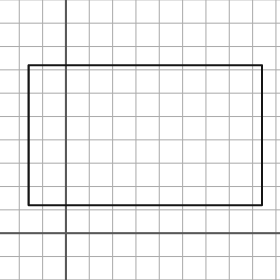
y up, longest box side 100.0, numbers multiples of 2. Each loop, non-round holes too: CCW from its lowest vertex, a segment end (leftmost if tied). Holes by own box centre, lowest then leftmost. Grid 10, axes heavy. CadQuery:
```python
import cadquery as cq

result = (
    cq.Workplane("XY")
    .moveTo(-16.0, 12.0)
    .lineTo(84.0, 12.0)
    .lineTo(84.0, 72.0)
    .lineTo(-16.0, 72.0)
    .close()
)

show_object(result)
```